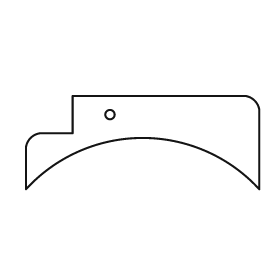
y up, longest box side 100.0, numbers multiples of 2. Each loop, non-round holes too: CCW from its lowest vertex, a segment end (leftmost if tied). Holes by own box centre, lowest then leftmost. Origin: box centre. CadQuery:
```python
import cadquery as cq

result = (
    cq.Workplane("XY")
    .moveTo(-50.0, -20.0)
    .threePointArc((0.0, 2.0), (50.0, -20.0))
    .lineTo(50.0, 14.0)
    .threePointArc((48.0, 18.0), (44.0, 20.0))
    .lineTo(-30.0, 20.0)
    .lineTo(-30.0, 4.0)
    .lineTo(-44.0, 4.0)
    .threePointArc((-48.0, 2.0), (-50.0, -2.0))
    .close()
    .moveTo(-14.0, 12.0)
    .circle(2.0)
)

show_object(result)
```